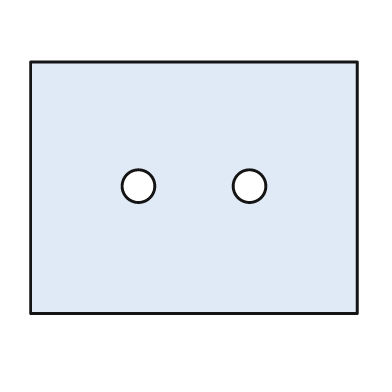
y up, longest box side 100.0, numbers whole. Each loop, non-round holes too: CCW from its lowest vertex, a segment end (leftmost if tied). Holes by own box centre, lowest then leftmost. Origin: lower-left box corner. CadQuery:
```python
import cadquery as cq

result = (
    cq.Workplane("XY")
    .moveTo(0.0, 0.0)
    .lineTo(100.0, 0.0)
    .lineTo(100.0, 77.0)
    .lineTo(0.0, 77.0)
    .close()
    .moveTo(33.0, 39.0)
    .circle(5.0)
    .moveTo(67.0, 39.0)
    .circle(5.0)
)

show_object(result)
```